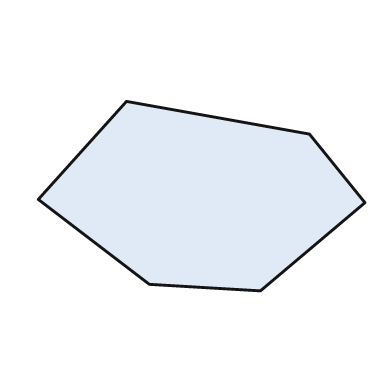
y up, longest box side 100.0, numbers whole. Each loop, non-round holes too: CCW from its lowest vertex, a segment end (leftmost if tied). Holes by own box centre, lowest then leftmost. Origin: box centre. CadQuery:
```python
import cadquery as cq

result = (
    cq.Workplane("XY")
    .moveTo(18.0, -29.0)
    .lineTo(50.0, -2.0)
    .lineTo(33.0, 19.0)
    .lineTo(-23.0, 29.0)
    .lineTo(-50.0, -1.0)
    .lineTo(-16.0, -27.0)
    .close()
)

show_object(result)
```